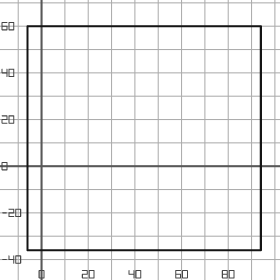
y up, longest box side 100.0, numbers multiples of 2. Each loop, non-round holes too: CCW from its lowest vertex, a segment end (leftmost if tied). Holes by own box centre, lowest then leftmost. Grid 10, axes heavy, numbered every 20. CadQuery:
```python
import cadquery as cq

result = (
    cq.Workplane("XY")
    .moveTo(-6.0, -36.0)
    .lineTo(94.0, -36.0)
    .lineTo(94.0, 60.0)
    .lineTo(-6.0, 60.0)
    .close()
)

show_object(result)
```